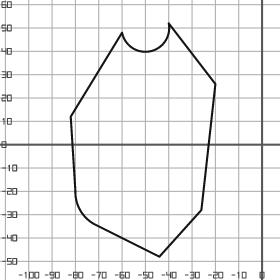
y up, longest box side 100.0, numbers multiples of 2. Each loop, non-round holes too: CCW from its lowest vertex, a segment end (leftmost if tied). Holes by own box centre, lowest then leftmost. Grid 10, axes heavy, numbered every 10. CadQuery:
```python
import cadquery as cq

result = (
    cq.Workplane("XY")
    .moveTo(-44.0, -48.0)
    .lineTo(-26.0, -28.0)
    .lineTo(-20.0, 26.0)
    .lineTo(-40.0, 52.0)
    .threePointArc((-48.0, 40.0), (-60.0, 48.0))
    .lineTo(-82.0, 12.0)
    .lineTo(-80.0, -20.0)
    .threePointArc((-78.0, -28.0), (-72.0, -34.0))
    .close()
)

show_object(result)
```